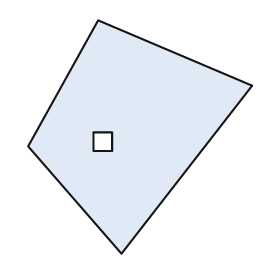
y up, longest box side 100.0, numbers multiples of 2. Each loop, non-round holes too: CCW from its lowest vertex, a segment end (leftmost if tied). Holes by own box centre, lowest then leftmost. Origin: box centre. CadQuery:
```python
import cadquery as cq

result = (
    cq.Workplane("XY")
    .moveTo(-8.0, -50.0)
    .lineTo(48.0, 22.0)
    .lineTo(-18.0, 50.0)
    .lineTo(-48.0, -4.0)
    .close()
    .moveTo(-20.0, -6.0)
    .lineTo(-12.0, -6.0)
    .lineTo(-12.0, 2.0)
    .lineTo(-20.0, 2.0)
    .close()
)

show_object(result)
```